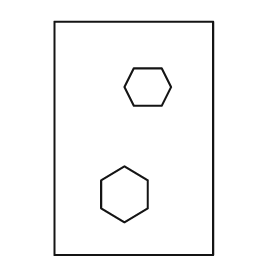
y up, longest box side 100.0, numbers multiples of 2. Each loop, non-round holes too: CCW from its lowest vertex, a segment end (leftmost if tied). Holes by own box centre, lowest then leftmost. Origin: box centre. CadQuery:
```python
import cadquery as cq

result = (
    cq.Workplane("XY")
    .moveTo(-34.0, -50.0)
    .lineTo(34.0, -50.0)
    .lineTo(34.0, 50.0)
    .lineTo(-34.0, 50.0)
    .close()
    .moveTo(-4.0, -36.0)
    .lineTo(6.0, -30.0)
    .lineTo(6.0, -18.0)
    .lineTo(-4.0, -12.0)
    .lineTo(-14.0, -18.0)
    .lineTo(-14.0, -30.0)
    .close()
    .moveTo(0.0, 14.0)
    .lineTo(12.0, 14.0)
    .lineTo(16.0, 22.0)
    .lineTo(12.0, 30.0)
    .lineTo(0.0, 30.0)
    .lineTo(-4.0, 22.0)
    .close()
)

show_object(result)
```